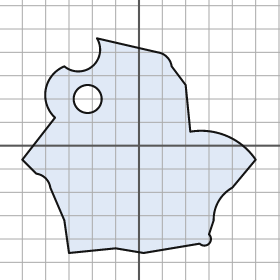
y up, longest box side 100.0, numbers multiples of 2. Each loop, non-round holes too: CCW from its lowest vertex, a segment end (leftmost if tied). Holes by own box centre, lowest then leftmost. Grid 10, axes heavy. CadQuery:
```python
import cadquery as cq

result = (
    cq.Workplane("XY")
    .moveTo(-30.0, -46.0)
    .lineTo(-10.0, -44.0)
    .lineTo(2.0, -46.0)
    .lineTo(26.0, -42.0)
    .threePointArc((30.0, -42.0), (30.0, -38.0))
    .lineTo(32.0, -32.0)
    .threePointArc((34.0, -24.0), (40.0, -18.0))
    .lineTo(50.0, -6.0)
    .threePointArc((38.0, 4.0), (22.0, 6.0))
    .lineTo(20.0, 26.0)
    .lineTo(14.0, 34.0)
    .threePointArc((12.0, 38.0), (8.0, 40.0))
    .lineTo(-18.0, 46.0)
    .threePointArc((-20.0, 34.0), (-32.0, 34.0))
    .threePointArc((-40.0, 24.0), (-36.0, 12.0))
    .lineTo(-50.0, -6.0)
    .lineTo(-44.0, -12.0)
    .threePointArc((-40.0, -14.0), (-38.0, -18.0))
    .lineTo(-32.0, -32.0)
    .close()
    .moveTo(-22.0, 20.0)
    .circle(6.0)
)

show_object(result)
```